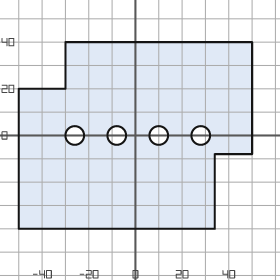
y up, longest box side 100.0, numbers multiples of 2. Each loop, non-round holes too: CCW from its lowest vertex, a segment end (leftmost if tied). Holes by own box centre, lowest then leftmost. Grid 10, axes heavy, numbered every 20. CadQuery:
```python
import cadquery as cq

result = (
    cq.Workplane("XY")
    .moveTo(-50.0, -40.0)
    .lineTo(34.0, -40.0)
    .lineTo(34.0, -8.0)
    .lineTo(50.0, -8.0)
    .lineTo(50.0, 40.0)
    .lineTo(-30.0, 40.0)
    .lineTo(-30.0, 20.0)
    .lineTo(-50.0, 20.0)
    .close()
    .moveTo(-26.0, 0.0)
    .circle(4.0)
    .moveTo(-8.0, 0.0)
    .circle(4.0)
    .moveTo(10.0, 0.0)
    .circle(4.0)
    .moveTo(28.0, 0.0)
    .circle(4.0)
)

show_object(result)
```